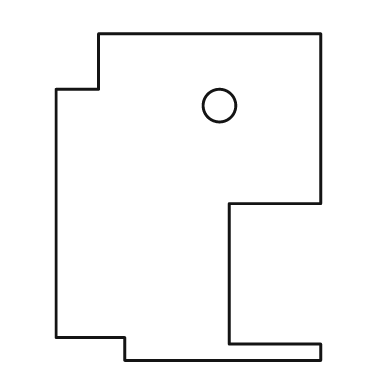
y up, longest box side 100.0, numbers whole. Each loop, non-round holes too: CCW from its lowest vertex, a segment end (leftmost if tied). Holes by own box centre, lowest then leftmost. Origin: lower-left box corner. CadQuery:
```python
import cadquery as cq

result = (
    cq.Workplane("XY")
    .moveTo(21.0, 0.0)
    .lineTo(81.0, 0.0)
    .lineTo(81.0, 5.0)
    .lineTo(53.0, 5.0)
    .lineTo(53.0, 48.0)
    .lineTo(81.0, 48.0)
    .lineTo(81.0, 100.0)
    .lineTo(13.0, 100.0)
    .lineTo(13.0, 83.0)
    .lineTo(0.0, 83.0)
    .lineTo(0.0, 7.0)
    .lineTo(21.0, 7.0)
    .close()
    .moveTo(50.0, 78.0)
    .circle(5.0)
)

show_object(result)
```